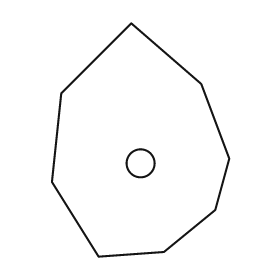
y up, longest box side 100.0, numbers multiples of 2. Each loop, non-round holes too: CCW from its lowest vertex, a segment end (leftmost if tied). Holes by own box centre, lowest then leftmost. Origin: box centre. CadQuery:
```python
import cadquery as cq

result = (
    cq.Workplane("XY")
    .moveTo(-18.0, -50.0)
    .lineTo(10.0, -48.0)
    .lineTo(32.0, -30.0)
    .lineTo(38.0, -8.0)
    .lineTo(26.0, 24.0)
    .lineTo(-4.0, 50.0)
    .lineTo(-34.0, 20.0)
    .lineTo(-38.0, -18.0)
    .close()
    .moveTo(0.0, -10.0)
    .circle(6.0)
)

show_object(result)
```